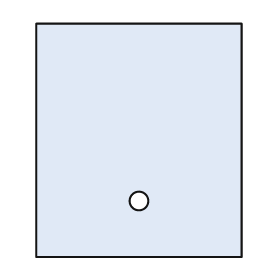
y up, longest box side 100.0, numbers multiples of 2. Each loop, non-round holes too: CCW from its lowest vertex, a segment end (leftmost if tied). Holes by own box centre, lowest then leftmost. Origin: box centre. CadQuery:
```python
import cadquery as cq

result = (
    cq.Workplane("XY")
    .moveTo(-44.0, -50.0)
    .lineTo(44.0, -50.0)
    .lineTo(44.0, 50.0)
    .lineTo(-44.0, 50.0)
    .close()
    .moveTo(0.0, -26.0)
    .circle(4.0)
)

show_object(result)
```